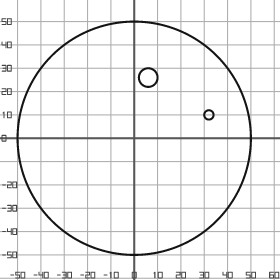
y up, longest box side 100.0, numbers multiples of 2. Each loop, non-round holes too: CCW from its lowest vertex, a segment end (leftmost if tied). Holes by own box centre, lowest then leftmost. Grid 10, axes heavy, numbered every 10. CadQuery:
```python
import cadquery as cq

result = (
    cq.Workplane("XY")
    .moveTo(0.0, 0.0)
    .circle(50.0)
    .moveTo(32.0, 10.0)
    .circle(2.0)
    .moveTo(6.0, 26.0)
    .circle(4.0)
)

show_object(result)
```